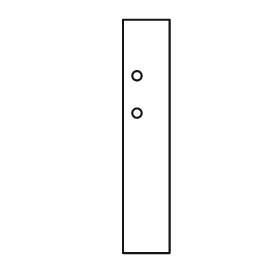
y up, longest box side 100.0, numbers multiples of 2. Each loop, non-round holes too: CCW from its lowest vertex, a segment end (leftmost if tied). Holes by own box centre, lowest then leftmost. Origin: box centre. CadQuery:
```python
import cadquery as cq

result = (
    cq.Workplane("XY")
    .moveTo(-10.0, -50.0)
    .lineTo(10.0, -50.0)
    .lineTo(10.0, 50.0)
    .lineTo(-10.0, 50.0)
    .close()
    .moveTo(-4.0, 10.0)
    .circle(2.0)
    .moveTo(-4.0, 26.0)
    .circle(2.0)
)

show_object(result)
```